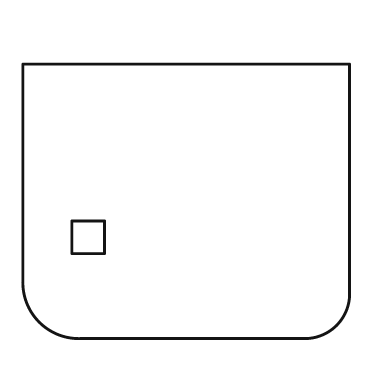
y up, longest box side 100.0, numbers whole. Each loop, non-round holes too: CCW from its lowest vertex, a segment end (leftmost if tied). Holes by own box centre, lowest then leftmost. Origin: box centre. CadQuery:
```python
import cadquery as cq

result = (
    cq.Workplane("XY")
    .moveTo(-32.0, -42.0)
    .lineTo(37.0, -42.0)
    .threePointArc((46.0, -38.0), (50.0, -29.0))
    .lineTo(50.0, 42.0)
    .lineTo(-50.0, 42.0)
    .lineTo(-50.0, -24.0)
    .threePointArc((-45.0, -37.0), (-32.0, -42.0))
    .close()
    .moveTo(-35.0, -16.0)
    .lineTo(-25.0, -16.0)
    .lineTo(-25.0, -6.0)
    .lineTo(-35.0, -6.0)
    .close()
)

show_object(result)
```